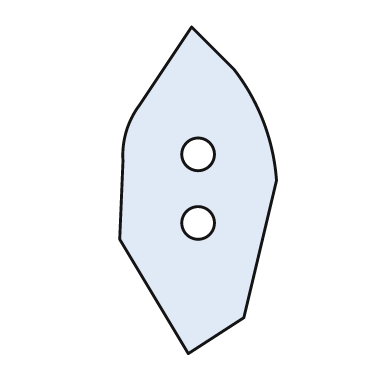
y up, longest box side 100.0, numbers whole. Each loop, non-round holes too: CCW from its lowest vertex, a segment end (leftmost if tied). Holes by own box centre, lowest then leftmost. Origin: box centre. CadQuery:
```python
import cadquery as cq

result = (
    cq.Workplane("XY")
    .moveTo(-3.0, -50.0)
    .lineTo(14.0, -39.0)
    .lineTo(24.0, 3.0)
    .threePointArc((20.0, 21.0), (11.0, 37.0))
    .lineTo(-2.0, 50.0)
    .lineTo(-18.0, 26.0)
    .threePointArc((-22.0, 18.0), (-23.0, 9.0))
    .lineTo(-24.0, -15.0)
    .close()
    .moveTo(0.0, -10.0)
    .circle(5.0)
    .moveTo(0.0, 11.0)
    .circle(5.0)
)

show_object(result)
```